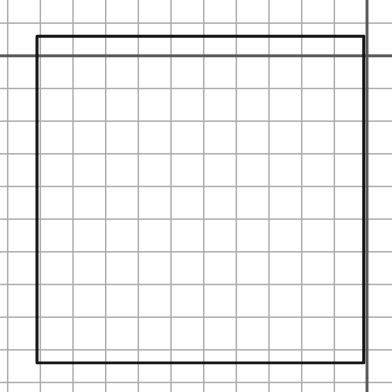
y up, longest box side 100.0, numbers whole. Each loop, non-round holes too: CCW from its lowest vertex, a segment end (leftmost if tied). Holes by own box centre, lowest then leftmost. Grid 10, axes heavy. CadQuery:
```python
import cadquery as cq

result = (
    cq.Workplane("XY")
    .moveTo(-101.0, -94.0)
    .lineTo(-1.0, -94.0)
    .lineTo(-1.0, 6.0)
    .lineTo(-101.0, 6.0)
    .close()
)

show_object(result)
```